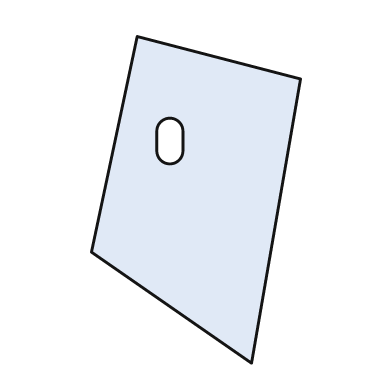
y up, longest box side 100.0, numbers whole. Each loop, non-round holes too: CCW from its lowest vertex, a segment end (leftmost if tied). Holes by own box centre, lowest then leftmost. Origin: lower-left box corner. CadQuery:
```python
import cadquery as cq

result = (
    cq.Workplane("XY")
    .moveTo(49.0, 0.0)
    .lineTo(64.0, 87.0)
    .lineTo(14.0, 100.0)
    .lineTo(0.0, 34.0)
    .close()
    .moveTo(20.0, 65.0)
    .threePointArc((24.0, 61.0), (28.0, 65.0))
    .lineTo(28.0, 71.0)
    .threePointArc((24.0, 75.0), (20.0, 71.0))
    .close()
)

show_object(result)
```